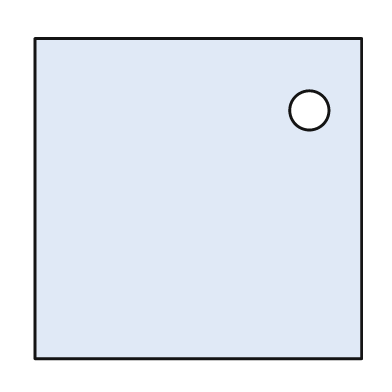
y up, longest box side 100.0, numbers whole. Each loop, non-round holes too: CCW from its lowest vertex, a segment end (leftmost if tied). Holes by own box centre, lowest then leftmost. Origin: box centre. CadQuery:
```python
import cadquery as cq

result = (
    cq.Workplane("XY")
    .moveTo(-50.0, -49.0)
    .lineTo(50.0, -49.0)
    .lineTo(50.0, 49.0)
    .lineTo(-50.0, 49.0)
    .close()
    .moveTo(34.0, 27.0)
    .circle(6.0)
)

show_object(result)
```